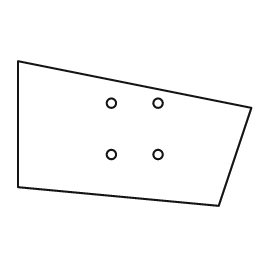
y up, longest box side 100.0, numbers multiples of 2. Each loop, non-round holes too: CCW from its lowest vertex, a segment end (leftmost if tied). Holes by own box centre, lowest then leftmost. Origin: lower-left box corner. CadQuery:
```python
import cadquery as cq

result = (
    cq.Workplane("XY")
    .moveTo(86.0, 0.0)
    .lineTo(100.0, 42.0)
    .lineTo(0.0, 62.0)
    .lineTo(0.0, 8.0)
    .close()
    .moveTo(40.0, 22.0)
    .circle(2.0)
    .moveTo(60.0, 22.0)
    .circle(2.0)
    .moveTo(40.0, 44.0)
    .circle(2.0)
    .moveTo(60.0, 44.0)
    .circle(2.0)
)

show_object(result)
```